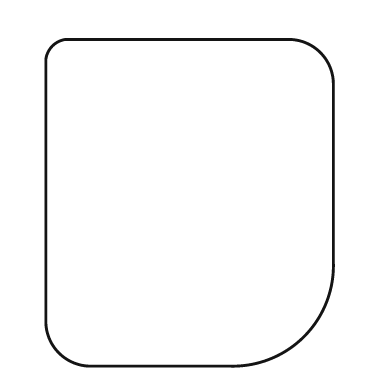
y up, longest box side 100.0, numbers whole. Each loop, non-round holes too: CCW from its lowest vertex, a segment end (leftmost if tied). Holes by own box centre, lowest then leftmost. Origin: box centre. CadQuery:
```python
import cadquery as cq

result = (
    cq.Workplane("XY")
    .moveTo(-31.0, -50.0)
    .lineTo(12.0, -50.0)
    .threePointArc((35.0, -41.0), (44.0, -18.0))
    .lineTo(44.0, 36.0)
    .threePointArc((40.0, 46.0), (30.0, 50.0))
    .lineTo(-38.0, 50.0)
    .threePointArc((-42.0, 48.0), (-44.0, 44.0))
    .lineTo(-44.0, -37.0)
    .threePointArc((-40.0, -46.0), (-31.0, -50.0))
    .close()
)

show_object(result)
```